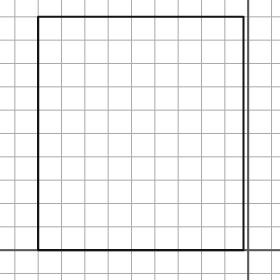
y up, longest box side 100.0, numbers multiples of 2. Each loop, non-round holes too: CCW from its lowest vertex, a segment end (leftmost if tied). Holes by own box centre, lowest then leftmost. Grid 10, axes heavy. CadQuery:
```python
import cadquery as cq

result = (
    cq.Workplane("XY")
    .moveTo(-90.0, 0.0)
    .lineTo(-2.0, 0.0)
    .lineTo(-2.0, 100.0)
    .lineTo(-90.0, 100.0)
    .close()
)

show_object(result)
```